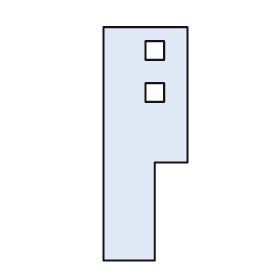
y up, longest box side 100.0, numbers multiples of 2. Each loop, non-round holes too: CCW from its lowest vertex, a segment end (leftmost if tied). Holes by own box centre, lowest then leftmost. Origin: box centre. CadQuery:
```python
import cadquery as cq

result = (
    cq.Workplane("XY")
    .moveTo(-18.0, -50.0)
    .lineTo(4.0, -50.0)
    .lineTo(4.0, -8.0)
    .lineTo(18.0, -8.0)
    .lineTo(18.0, 50.0)
    .lineTo(-18.0, 50.0)
    .close()
    .moveTo(0.0, 18.0)
    .lineTo(8.0, 18.0)
    .lineTo(8.0, 26.0)
    .lineTo(0.0, 26.0)
    .close()
    .moveTo(0.0, 36.0)
    .lineTo(8.0, 36.0)
    .lineTo(8.0, 44.0)
    .lineTo(0.0, 44.0)
    .close()
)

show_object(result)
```